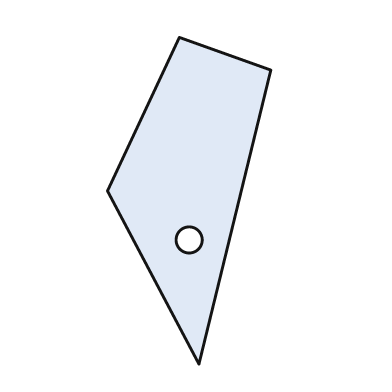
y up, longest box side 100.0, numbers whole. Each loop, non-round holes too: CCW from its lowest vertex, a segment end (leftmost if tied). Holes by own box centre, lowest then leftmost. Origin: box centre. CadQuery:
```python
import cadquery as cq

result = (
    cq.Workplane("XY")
    .moveTo(3.0, -50.0)
    .lineTo(25.0, 40.0)
    .lineTo(-3.0, 50.0)
    .lineTo(-25.0, 3.0)
    .close()
    .moveTo(0.0, -12.0)
    .circle(4.0)
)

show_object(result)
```